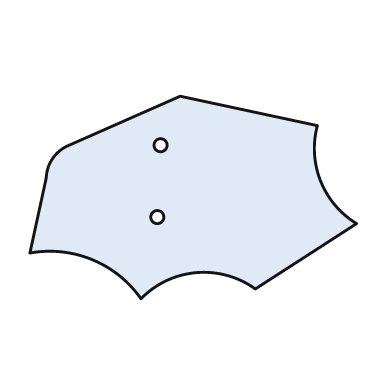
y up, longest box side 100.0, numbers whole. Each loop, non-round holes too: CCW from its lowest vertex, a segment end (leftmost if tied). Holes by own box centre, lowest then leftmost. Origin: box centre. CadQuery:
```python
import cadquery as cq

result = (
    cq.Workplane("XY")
    .moveTo(-16.0, -31.0)
    .threePointArc((1.0, -23.0), (19.0, -28.0))
    .lineTo(50.0, -8.0)
    .threePointArc((39.0, 5.0), (38.0, 22.0))
    .lineTo(-4.0, 31.0)
    .lineTo(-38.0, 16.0)
    .threePointArc((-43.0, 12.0), (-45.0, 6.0))
    .lineTo(-50.0, -17.0)
    .threePointArc((-31.0, -19.0), (-16.0, -31.0))
    .close()
    .moveTo(-11.0, -6.0)
    .circle(2.0)
    .moveTo(-10.0, 16.0)
    .circle(2.0)
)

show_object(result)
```